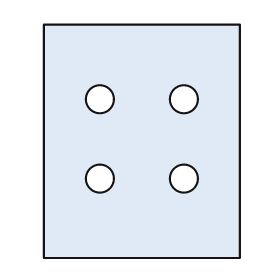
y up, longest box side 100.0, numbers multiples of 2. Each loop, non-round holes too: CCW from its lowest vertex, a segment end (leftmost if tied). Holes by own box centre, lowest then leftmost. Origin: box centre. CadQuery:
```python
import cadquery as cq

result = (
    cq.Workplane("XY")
    .moveTo(-42.0, -50.0)
    .lineTo(42.0, -50.0)
    .lineTo(42.0, 50.0)
    .lineTo(-42.0, 50.0)
    .close()
    .moveTo(-18.0, -16.0)
    .circle(6.0)
    .moveTo(18.0, -16.0)
    .circle(6.0)
    .moveTo(-18.0, 18.0)
    .circle(6.0)
    .moveTo(18.0, 18.0)
    .circle(6.0)
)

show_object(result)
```